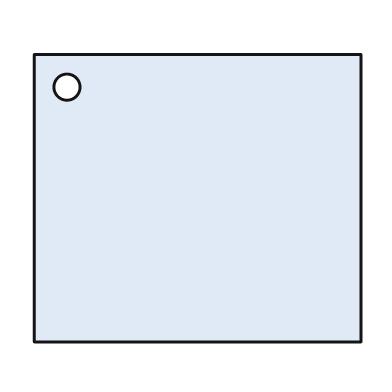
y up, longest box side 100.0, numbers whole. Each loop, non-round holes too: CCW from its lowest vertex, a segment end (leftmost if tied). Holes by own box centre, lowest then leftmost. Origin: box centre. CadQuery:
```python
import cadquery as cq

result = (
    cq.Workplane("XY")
    .moveTo(-50.0, -44.0)
    .lineTo(50.0, -44.0)
    .lineTo(50.0, 44.0)
    .lineTo(-50.0, 44.0)
    .close()
    .moveTo(-40.0, 34.0)
    .circle(4.0)
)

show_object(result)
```